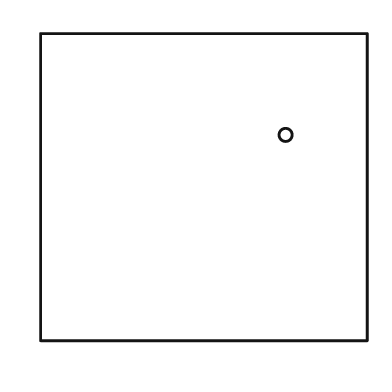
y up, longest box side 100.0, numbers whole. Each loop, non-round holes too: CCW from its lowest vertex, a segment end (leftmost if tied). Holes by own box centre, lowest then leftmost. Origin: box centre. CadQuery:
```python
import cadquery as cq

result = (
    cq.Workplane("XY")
    .moveTo(-50.0, -47.0)
    .lineTo(50.0, -47.0)
    .lineTo(50.0, 47.0)
    .lineTo(-50.0, 47.0)
    .close()
    .moveTo(25.0, 16.0)
    .circle(2.0)
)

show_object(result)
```